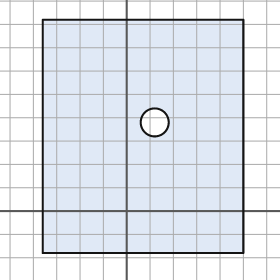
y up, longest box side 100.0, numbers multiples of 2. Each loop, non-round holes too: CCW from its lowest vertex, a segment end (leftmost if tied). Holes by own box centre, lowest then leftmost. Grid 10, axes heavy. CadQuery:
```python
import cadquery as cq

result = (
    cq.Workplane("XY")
    .moveTo(-36.0, -18.0)
    .lineTo(50.0, -18.0)
    .lineTo(50.0, 82.0)
    .lineTo(-36.0, 82.0)
    .close()
    .moveTo(12.0, 38.0)
    .circle(6.0)
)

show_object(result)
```